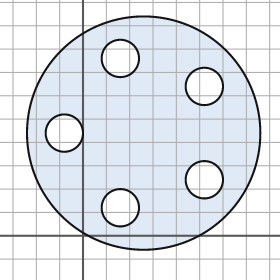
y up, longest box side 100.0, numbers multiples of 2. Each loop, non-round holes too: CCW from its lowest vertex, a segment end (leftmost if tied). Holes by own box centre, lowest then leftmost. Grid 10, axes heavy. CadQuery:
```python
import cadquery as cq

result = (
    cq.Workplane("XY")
    .moveTo(26.0, 44.0)
    .circle(50.0)
    .moveTo(16.0, 12.0)
    .circle(8.0)
    .moveTo(52.0, 24.0)
    .circle(8.0)
    .moveTo(-8.0, 44.0)
    .circle(8.0)
    .moveTo(52.0, 64.0)
    .circle(8.0)
    .moveTo(16.0, 76.0)
    .circle(8.0)
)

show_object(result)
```